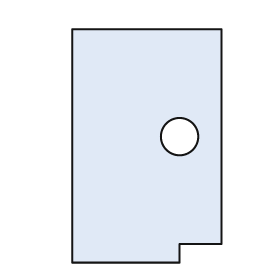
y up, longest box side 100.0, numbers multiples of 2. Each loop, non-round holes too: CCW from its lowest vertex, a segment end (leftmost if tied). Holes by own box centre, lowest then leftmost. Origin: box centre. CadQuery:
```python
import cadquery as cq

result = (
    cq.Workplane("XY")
    .moveTo(-32.0, -50.0)
    .lineTo(14.0, -50.0)
    .lineTo(14.0, -42.0)
    .lineTo(32.0, -42.0)
    .lineTo(32.0, 50.0)
    .lineTo(-32.0, 50.0)
    .close()
    .moveTo(14.0, 4.0)
    .circle(8.0)
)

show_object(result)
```